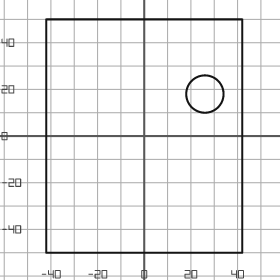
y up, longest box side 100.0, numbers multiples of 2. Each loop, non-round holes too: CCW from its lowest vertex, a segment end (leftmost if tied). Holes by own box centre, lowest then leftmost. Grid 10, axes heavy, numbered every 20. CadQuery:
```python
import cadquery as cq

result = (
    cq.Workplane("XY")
    .moveTo(-42.0, -50.0)
    .lineTo(42.0, -50.0)
    .lineTo(42.0, 50.0)
    .lineTo(-42.0, 50.0)
    .close()
    .moveTo(26.0, 18.0)
    .circle(8.0)
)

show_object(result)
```